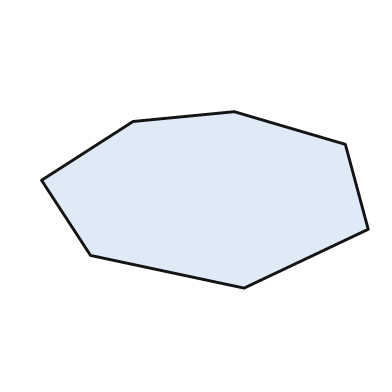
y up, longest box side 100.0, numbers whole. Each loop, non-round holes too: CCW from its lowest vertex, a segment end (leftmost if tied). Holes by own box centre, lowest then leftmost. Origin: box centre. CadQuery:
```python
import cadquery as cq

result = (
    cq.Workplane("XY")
    .moveTo(12.0, -27.0)
    .lineTo(50.0, -9.0)
    .lineTo(43.0, 17.0)
    .lineTo(9.0, 27.0)
    .lineTo(-22.0, 24.0)
    .lineTo(-50.0, 6.0)
    .lineTo(-35.0, -17.0)
    .close()
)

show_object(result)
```